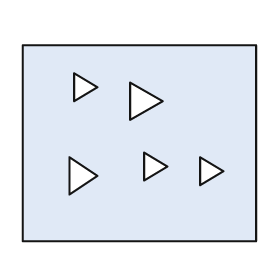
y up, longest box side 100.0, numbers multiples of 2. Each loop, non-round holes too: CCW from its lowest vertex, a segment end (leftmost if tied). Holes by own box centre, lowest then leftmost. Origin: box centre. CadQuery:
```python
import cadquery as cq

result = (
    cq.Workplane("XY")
    .moveTo(-50.0, -42.0)
    .lineTo(50.0, -42.0)
    .lineTo(50.0, 42.0)
    .lineTo(-50.0, 42.0)
    .close()
    .moveTo(-30.0, -22.0)
    .lineTo(-18.0, -14.0)
    .lineTo(-30.0, -6.0)
    .close()
    .moveTo(26.0, -18.0)
    .lineTo(36.0, -12.0)
    .lineTo(26.0, -6.0)
    .close()
    .moveTo(2.0, -16.0)
    .lineTo(12.0, -10.0)
    .lineTo(2.0, -4.0)
    .close()
    .moveTo(-4.0, 10.0)
    .lineTo(10.0, 18.0)
    .lineTo(-4.0, 26.0)
    .close()
    .moveTo(-28.0, 18.0)
    .lineTo(-18.0, 24.0)
    .lineTo(-28.0, 30.0)
    .close()
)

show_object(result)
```